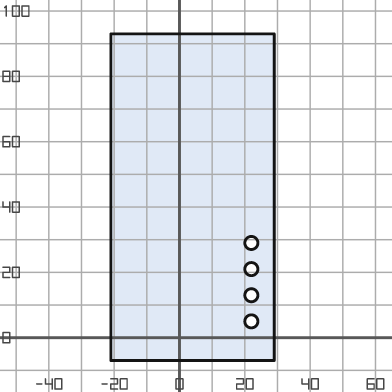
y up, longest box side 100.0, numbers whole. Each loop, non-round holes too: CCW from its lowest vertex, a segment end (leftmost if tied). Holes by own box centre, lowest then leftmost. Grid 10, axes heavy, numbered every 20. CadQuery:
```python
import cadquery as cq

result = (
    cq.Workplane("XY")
    .moveTo(-21.0, -7.0)
    .lineTo(29.0, -7.0)
    .lineTo(29.0, 93.0)
    .lineTo(-21.0, 93.0)
    .close()
    .moveTo(22.0, 5.0)
    .circle(2.0)
    .moveTo(22.0, 13.0)
    .circle(2.0)
    .moveTo(22.0, 21.0)
    .circle(2.0)
    .moveTo(22.0, 29.0)
    .circle(2.0)
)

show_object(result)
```